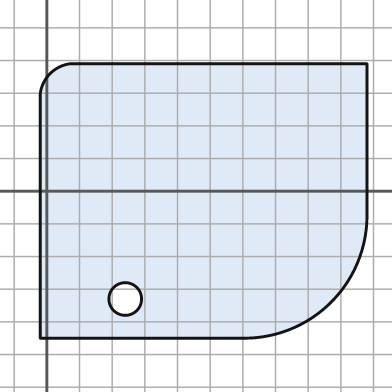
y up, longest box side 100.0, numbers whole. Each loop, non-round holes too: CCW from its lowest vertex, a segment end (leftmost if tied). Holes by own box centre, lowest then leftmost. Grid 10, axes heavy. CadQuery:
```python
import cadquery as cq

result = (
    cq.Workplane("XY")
    .moveTo(-2.0, -45.0)
    .lineTo(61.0, -45.0)
    .threePointArc((87.0, -34.0), (98.0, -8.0))
    .lineTo(98.0, 39.0)
    .lineTo(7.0, 39.0)
    .threePointArc((1.0, 36.0), (-2.0, 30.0))
    .close()
    .moveTo(24.0, -33.0)
    .circle(5.0)
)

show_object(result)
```